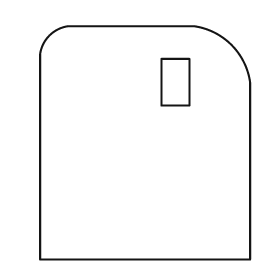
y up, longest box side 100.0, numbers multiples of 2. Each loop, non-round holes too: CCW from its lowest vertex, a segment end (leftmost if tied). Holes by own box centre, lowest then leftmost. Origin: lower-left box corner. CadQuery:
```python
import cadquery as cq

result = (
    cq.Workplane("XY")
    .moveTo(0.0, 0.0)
    .lineTo(90.0, 0.0)
    .lineTo(90.0, 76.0)
    .threePointArc((82.0, 92.0), (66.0, 100.0))
    .lineTo(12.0, 100.0)
    .threePointArc((4.0, 96.0), (0.0, 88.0))
    .close()
    .moveTo(52.0, 66.0)
    .lineTo(64.0, 66.0)
    .lineTo(64.0, 86.0)
    .lineTo(52.0, 86.0)
    .close()
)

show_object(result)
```